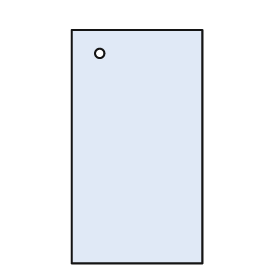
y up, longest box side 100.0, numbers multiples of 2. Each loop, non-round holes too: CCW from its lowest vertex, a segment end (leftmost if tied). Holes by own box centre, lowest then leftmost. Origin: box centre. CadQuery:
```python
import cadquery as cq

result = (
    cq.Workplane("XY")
    .moveTo(-28.0, -50.0)
    .lineTo(28.0, -50.0)
    .lineTo(28.0, 50.0)
    .lineTo(-28.0, 50.0)
    .close()
    .moveTo(-16.0, 40.0)
    .circle(2.0)
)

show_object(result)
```